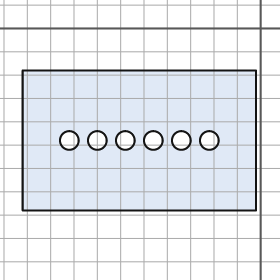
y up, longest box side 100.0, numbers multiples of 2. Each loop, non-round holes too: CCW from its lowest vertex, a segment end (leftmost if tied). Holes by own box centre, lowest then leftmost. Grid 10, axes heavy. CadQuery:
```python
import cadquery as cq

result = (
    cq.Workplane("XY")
    .moveTo(-102.0, -78.0)
    .lineTo(-2.0, -78.0)
    .lineTo(-2.0, -18.0)
    .lineTo(-102.0, -18.0)
    .close()
    .moveTo(-82.0, -48.0)
    .circle(4.0)
    .moveTo(-70.0, -48.0)
    .circle(4.0)
    .moveTo(-58.0, -48.0)
    .circle(4.0)
    .moveTo(-46.0, -48.0)
    .circle(4.0)
    .moveTo(-34.0, -48.0)
    .circle(4.0)
    .moveTo(-22.0, -48.0)
    .circle(4.0)
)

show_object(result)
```